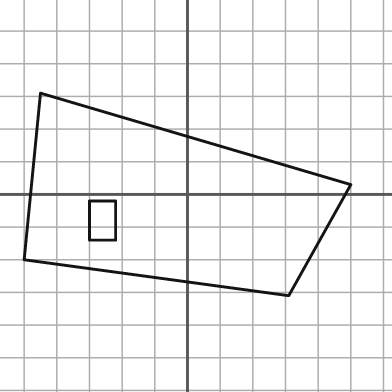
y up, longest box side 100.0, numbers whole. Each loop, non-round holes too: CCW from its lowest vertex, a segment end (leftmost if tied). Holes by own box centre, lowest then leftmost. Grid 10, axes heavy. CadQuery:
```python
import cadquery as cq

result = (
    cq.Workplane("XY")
    .moveTo(31.0, -31.0)
    .lineTo(50.0, 3.0)
    .lineTo(-45.0, 31.0)
    .lineTo(-50.0, -20.0)
    .close()
    .moveTo(-30.0, -14.0)
    .lineTo(-22.0, -14.0)
    .lineTo(-22.0, -2.0)
    .lineTo(-30.0, -2.0)
    .close()
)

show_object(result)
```